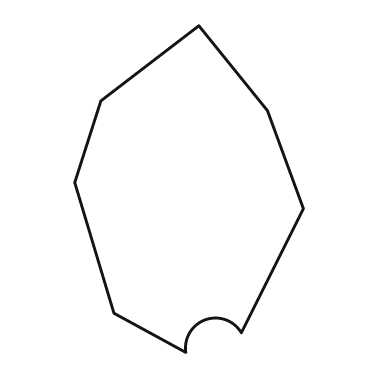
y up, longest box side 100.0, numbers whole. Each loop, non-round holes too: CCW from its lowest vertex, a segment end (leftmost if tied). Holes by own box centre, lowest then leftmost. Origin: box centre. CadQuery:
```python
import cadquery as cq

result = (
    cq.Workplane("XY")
    .moveTo(-1.0, -50.0)
    .threePointArc((5.0, -40.0), (16.0, -44.0))
    .lineTo(35.0, -6.0)
    .lineTo(24.0, 24.0)
    .lineTo(3.0, 50.0)
    .lineTo(-27.0, 27.0)
    .lineTo(-35.0, 2.0)
    .lineTo(-23.0, -38.0)
    .close()
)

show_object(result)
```